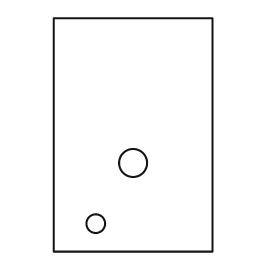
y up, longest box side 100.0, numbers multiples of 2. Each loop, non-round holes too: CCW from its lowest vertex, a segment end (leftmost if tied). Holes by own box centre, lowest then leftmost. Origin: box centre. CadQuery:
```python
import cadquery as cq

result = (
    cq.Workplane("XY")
    .moveTo(-34.0, -50.0)
    .lineTo(34.0, -50.0)
    .lineTo(34.0, 50.0)
    .lineTo(-34.0, 50.0)
    .close()
    .moveTo(-16.0, -38.0)
    .circle(4.0)
    .moveTo(0.0, -12.0)
    .circle(6.0)
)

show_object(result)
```